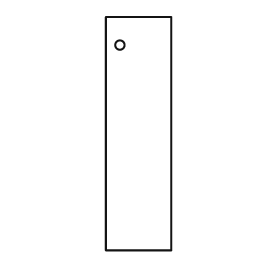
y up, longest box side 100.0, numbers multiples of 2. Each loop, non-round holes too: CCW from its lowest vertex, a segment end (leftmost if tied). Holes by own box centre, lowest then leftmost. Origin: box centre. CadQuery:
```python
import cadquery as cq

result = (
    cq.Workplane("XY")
    .moveTo(-14.0, -50.0)
    .lineTo(14.0, -50.0)
    .lineTo(14.0, 50.0)
    .lineTo(-14.0, 50.0)
    .close()
    .moveTo(-8.0, 38.0)
    .circle(2.0)
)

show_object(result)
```